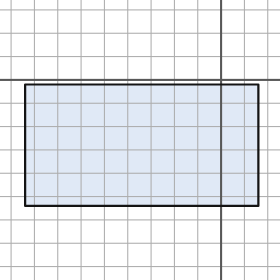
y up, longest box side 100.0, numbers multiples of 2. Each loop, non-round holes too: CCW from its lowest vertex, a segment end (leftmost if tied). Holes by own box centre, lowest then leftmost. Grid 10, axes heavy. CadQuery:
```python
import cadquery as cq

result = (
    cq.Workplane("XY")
    .moveTo(-84.0, -54.0)
    .lineTo(16.0, -54.0)
    .lineTo(16.0, -2.0)
    .lineTo(-84.0, -2.0)
    .close()
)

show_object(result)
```